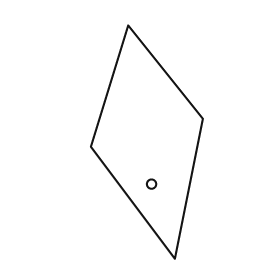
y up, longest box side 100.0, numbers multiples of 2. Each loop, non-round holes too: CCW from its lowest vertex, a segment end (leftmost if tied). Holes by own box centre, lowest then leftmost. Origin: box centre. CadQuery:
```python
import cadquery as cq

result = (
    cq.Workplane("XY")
    .moveTo(12.0, -50.0)
    .lineTo(24.0, 10.0)
    .lineTo(-8.0, 50.0)
    .lineTo(-24.0, -2.0)
    .close()
    .moveTo(2.0, -18.0)
    .circle(2.0)
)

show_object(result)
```